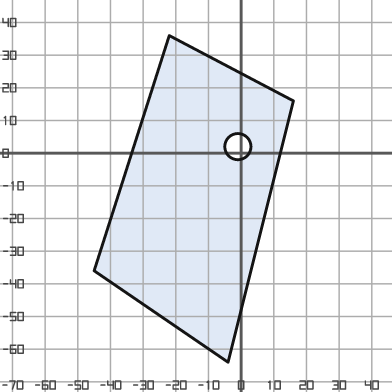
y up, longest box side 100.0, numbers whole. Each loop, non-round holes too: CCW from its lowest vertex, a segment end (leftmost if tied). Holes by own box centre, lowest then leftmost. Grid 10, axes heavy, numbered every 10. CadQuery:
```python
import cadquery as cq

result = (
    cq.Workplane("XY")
    .moveTo(-4.0, -64.0)
    .lineTo(16.0, 16.0)
    .lineTo(-22.0, 36.0)
    .lineTo(-45.0, -36.0)
    .close()
    .moveTo(-1.0, 2.0)
    .circle(4.0)
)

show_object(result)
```